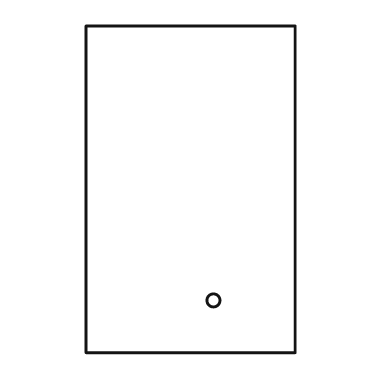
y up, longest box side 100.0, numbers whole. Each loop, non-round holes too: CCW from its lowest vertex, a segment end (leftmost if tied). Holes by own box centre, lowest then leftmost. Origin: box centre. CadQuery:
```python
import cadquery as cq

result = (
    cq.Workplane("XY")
    .moveTo(-32.0, -50.0)
    .lineTo(32.0, -50.0)
    .lineTo(32.0, 50.0)
    .lineTo(-32.0, 50.0)
    .close()
    .moveTo(7.0, -34.0)
    .circle(2.0)
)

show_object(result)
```